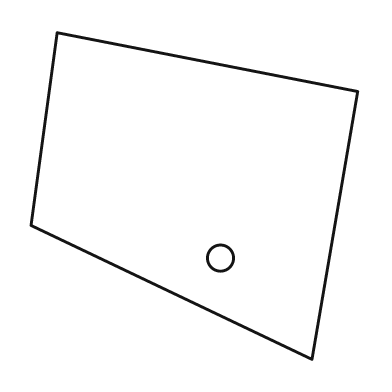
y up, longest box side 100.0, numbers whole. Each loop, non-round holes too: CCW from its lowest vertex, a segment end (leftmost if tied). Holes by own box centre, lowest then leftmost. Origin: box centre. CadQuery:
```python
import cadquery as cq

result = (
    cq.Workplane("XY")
    .moveTo(36.0, -50.0)
    .lineTo(50.0, 32.0)
    .lineTo(-42.0, 50.0)
    .lineTo(-50.0, -9.0)
    .close()
    .moveTo(8.0, -19.0)
    .circle(4.0)
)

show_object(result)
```